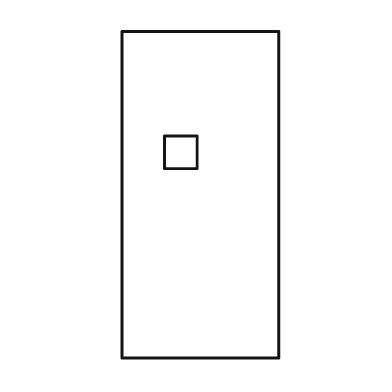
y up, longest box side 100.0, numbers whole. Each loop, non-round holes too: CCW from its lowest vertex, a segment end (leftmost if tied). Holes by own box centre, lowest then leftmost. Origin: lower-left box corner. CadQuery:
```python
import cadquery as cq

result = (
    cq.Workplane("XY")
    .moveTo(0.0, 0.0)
    .lineTo(48.0, 0.0)
    .lineTo(48.0, 100.0)
    .lineTo(0.0, 100.0)
    .close()
    .moveTo(13.0, 58.0)
    .lineTo(23.0, 58.0)
    .lineTo(23.0, 68.0)
    .lineTo(13.0, 68.0)
    .close()
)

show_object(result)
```